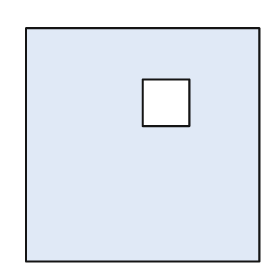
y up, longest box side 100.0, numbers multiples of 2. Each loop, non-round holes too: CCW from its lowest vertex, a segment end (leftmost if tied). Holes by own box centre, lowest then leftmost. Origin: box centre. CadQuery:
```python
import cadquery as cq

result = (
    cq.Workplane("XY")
    .moveTo(-50.0, -50.0)
    .lineTo(50.0, -50.0)
    .lineTo(50.0, 50.0)
    .lineTo(-50.0, 50.0)
    .close()
    .moveTo(0.0, 8.0)
    .lineTo(20.0, 8.0)
    .lineTo(20.0, 28.0)
    .lineTo(0.0, 28.0)
    .close()
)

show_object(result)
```